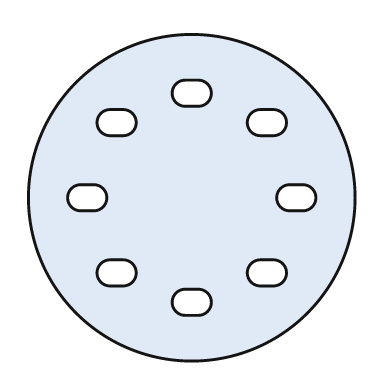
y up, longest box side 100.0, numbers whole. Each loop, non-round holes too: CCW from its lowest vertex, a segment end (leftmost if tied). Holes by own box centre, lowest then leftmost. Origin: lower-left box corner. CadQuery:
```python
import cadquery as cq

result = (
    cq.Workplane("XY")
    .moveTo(50.0, 50.0)
    .circle(50.0)
    .moveTo(48.0, 14.0)
    .lineTo(52.0, 14.0)
    .threePointArc((56.0, 18.0), (52.0, 22.0))
    .lineTo(48.0, 22.0)
    .threePointArc((44.0, 18.0), (48.0, 14.0))
    .close()
    .moveTo(25.0, 23.0)
    .lineTo(29.0, 23.0)
    .threePointArc((33.0, 27.0), (29.0, 31.0))
    .lineTo(25.0, 31.0)
    .threePointArc((21.0, 27.0), (25.0, 23.0))
    .close()
    .moveTo(71.0, 23.0)
    .lineTo(75.0, 23.0)
    .threePointArc((79.0, 27.0), (75.0, 31.0))
    .lineTo(71.0, 31.0)
    .threePointArc((67.0, 27.0), (71.0, 23.0))
    .close()
    .moveTo(16.0, 46.0)
    .lineTo(20.0, 46.0)
    .threePointArc((24.0, 50.0), (20.0, 54.0))
    .lineTo(16.0, 54.0)
    .threePointArc((12.0, 50.0), (16.0, 46.0))
    .close()
    .moveTo(80.0, 46.0)
    .lineTo(84.0, 46.0)
    .threePointArc((88.0, 50.0), (84.0, 54.0))
    .lineTo(80.0, 54.0)
    .threePointArc((76.0, 50.0), (80.0, 46.0))
    .close()
    .moveTo(25.0, 69.0)
    .lineTo(29.0, 69.0)
    .threePointArc((33.0, 73.0), (29.0, 77.0))
    .lineTo(25.0, 77.0)
    .threePointArc((21.0, 73.0), (25.0, 69.0))
    .close()
    .moveTo(71.0, 69.0)
    .lineTo(75.0, 69.0)
    .threePointArc((79.0, 73.0), (75.0, 77.0))
    .lineTo(71.0, 77.0)
    .threePointArc((67.0, 73.0), (71.0, 69.0))
    .close()
    .moveTo(48.0, 78.0)
    .lineTo(52.0, 78.0)
    .threePointArc((56.0, 82.0), (52.0, 86.0))
    .lineTo(48.0, 86.0)
    .threePointArc((44.0, 82.0), (48.0, 78.0))
    .close()
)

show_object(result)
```